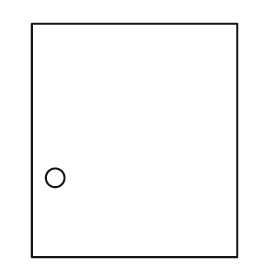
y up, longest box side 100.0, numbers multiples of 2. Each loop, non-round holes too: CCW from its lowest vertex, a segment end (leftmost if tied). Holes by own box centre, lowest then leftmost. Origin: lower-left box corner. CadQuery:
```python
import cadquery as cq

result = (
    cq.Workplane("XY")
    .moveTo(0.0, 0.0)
    .lineTo(88.0, 0.0)
    .lineTo(88.0, 100.0)
    .lineTo(0.0, 100.0)
    .close()
    .moveTo(10.0, 34.0)
    .circle(4.0)
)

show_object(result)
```